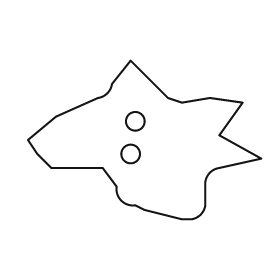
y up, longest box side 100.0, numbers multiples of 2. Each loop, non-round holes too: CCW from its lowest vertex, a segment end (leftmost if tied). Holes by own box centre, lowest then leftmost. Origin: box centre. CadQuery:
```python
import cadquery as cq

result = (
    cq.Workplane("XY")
    .moveTo(16.0, -34.0)
    .lineTo(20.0, -34.0)
    .threePointArc((24.0, -32.0), (26.0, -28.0))
    .lineTo(26.0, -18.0)
    .threePointArc((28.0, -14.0), (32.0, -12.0))
    .lineTo(50.0, -8.0)
    .lineTo(32.0, 2.0)
    .lineTo(42.0, 16.0)
    .lineTo(28.0, 18.0)
    .lineTo(16.0, 16.0)
    .lineTo(10.0, 18.0)
    .lineTo(-6.0, 34.0)
    .lineTo(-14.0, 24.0)
    .threePointArc((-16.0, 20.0), (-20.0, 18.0))
    .lineTo(-38.0, 10.0)
    .lineTo(-50.0, 0.0)
    .lineTo(-46.0, -6.0)
    .lineTo(-40.0, -12.0)
    .lineTo(-18.0, -12.0)
    .lineTo(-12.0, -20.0)
    .threePointArc((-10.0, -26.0), (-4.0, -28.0))
    .lineTo(0.0, -30.0)
    .close()
    .moveTo(-6.0, -6.0)
    .circle(4.0)
    .moveTo(-4.0, 8.0)
    .circle(4.0)
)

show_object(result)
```